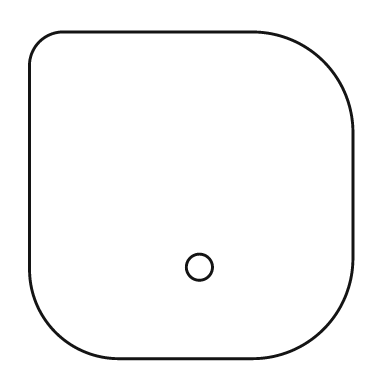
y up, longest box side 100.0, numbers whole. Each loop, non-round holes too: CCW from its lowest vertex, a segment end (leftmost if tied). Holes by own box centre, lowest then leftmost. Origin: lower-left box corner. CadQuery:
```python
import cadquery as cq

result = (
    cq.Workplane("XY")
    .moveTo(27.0, 0.0)
    .lineTo(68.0, 0.0)
    .threePointArc((90.0, 9.0), (99.0, 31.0))
    .lineTo(99.0, 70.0)
    .threePointArc((90.0, 91.0), (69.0, 100.0))
    .lineTo(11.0, 100.0)
    .threePointArc((3.0, 97.0), (0.0, 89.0))
    .lineTo(0.0, 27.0)
    .threePointArc((8.0, 8.0), (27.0, 0.0))
    .close()
    .moveTo(52.0, 28.0)
    .circle(4.0)
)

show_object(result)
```